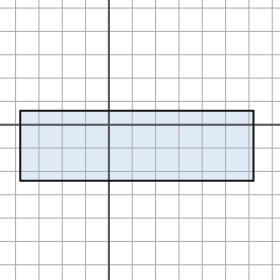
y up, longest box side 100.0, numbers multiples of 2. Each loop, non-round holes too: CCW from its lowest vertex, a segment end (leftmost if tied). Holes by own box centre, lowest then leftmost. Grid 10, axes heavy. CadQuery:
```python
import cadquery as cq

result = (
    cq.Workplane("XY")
    .moveTo(-38.0, -24.0)
    .lineTo(62.0, -24.0)
    .lineTo(62.0, 6.0)
    .lineTo(-38.0, 6.0)
    .close()
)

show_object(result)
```